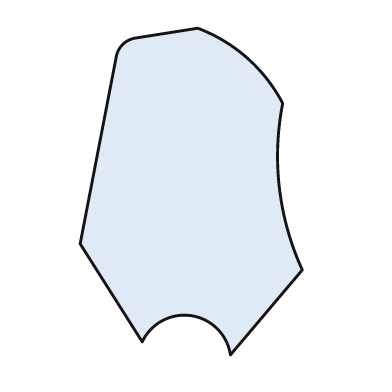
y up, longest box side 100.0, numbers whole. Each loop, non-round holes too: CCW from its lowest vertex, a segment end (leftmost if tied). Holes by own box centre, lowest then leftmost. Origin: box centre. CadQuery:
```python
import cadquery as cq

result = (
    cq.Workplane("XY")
    .moveTo(12.0, -50.0)
    .lineTo(34.0, -24.0)
    .threePointArc((27.0, 1.0), (28.0, 27.0))
    .threePointArc((17.0, 41.0), (2.0, 50.0))
    .lineTo(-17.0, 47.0)
    .threePointArc((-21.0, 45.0), (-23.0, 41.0))
    .lineTo(-34.0, -16.0)
    .lineTo(-15.0, -46.0)
    .threePointArc((0.0, -38.0), (12.0, -50.0))
    .close()
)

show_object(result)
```